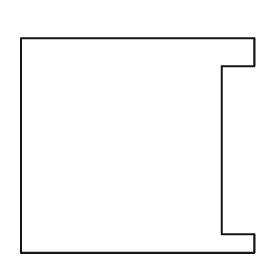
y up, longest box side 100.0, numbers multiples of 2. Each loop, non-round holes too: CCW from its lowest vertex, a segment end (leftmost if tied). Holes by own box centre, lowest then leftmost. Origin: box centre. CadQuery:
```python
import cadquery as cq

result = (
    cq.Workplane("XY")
    .moveTo(-50.0, -46.0)
    .lineTo(50.0, -46.0)
    .lineTo(50.0, -38.0)
    .lineTo(36.0, -38.0)
    .lineTo(36.0, 34.0)
    .lineTo(50.0, 34.0)
    .lineTo(50.0, 46.0)
    .lineTo(-50.0, 46.0)
    .close()
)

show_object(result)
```